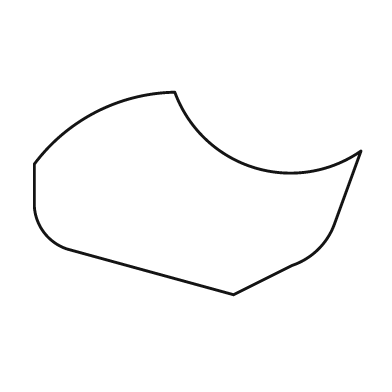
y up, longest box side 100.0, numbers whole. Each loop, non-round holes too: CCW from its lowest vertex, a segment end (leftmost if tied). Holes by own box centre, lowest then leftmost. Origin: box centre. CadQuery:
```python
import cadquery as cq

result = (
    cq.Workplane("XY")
    .moveTo(11.0, -31.0)
    .lineTo(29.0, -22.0)
    .threePointArc((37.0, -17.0), (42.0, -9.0))
    .lineTo(50.0, 13.0)
    .threePointArc((17.0, 8.0), (-7.0, 31.0))
    .threePointArc((-31.0, 25.0), (-50.0, 9.0))
    .lineTo(-50.0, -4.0)
    .threePointArc((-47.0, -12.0), (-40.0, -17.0))
    .close()
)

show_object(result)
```